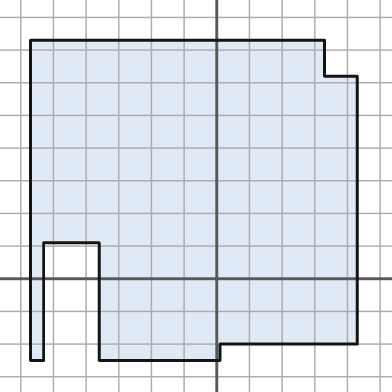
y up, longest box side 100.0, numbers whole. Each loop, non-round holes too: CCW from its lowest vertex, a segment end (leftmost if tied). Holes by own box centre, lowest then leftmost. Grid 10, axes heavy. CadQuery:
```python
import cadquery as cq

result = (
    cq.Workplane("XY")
    .moveTo(-57.0, -25.0)
    .lineTo(-53.0, -25.0)
    .lineTo(-53.0, 11.0)
    .lineTo(-36.0, 11.0)
    .lineTo(-36.0, -25.0)
    .lineTo(1.0, -25.0)
    .lineTo(1.0, -20.0)
    .lineTo(43.0, -20.0)
    .lineTo(43.0, 62.0)
    .lineTo(33.0, 62.0)
    .lineTo(33.0, 73.0)
    .lineTo(-57.0, 73.0)
    .close()
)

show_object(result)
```